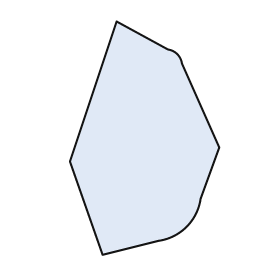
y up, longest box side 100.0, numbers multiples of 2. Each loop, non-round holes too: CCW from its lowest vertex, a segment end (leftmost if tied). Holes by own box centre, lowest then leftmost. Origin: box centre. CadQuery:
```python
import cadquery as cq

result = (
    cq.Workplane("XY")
    .moveTo(-18.0, -50.0)
    .lineTo(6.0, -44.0)
    .threePointArc((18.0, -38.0), (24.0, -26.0))
    .lineTo(32.0, -4.0)
    .lineTo(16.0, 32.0)
    .threePointArc((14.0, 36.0), (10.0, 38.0))
    .lineTo(-12.0, 50.0)
    .lineTo(-32.0, -10.0)
    .close()
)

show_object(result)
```